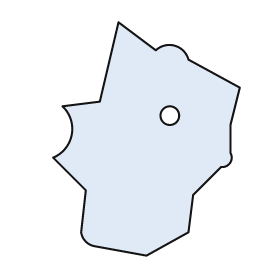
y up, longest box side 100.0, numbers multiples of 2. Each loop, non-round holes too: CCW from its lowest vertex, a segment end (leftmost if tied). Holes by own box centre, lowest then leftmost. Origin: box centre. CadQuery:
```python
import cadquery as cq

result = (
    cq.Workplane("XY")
    .moveTo(0.0, -50.0)
    .lineTo(18.0, -40.0)
    .lineTo(20.0, -24.0)
    .lineTo(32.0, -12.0)
    .threePointArc((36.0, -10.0), (36.0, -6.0))
    .lineTo(36.0, 6.0)
    .lineTo(40.0, 22.0)
    .lineTo(18.0, 34.0)
    .threePointArc((12.0, 40.0), (4.0, 38.0))
    .lineTo(-12.0, 50.0)
    .lineTo(-20.0, 16.0)
    .lineTo(-36.0, 14.0)
    .threePointArc((-32.0, 2.0), (-40.0, -8.0))
    .lineTo(-26.0, -22.0)
    .lineTo(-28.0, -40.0)
    .threePointArc((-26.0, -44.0), (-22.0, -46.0))
    .close()
    .moveTo(10.0, 10.0)
    .circle(4.0)
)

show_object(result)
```